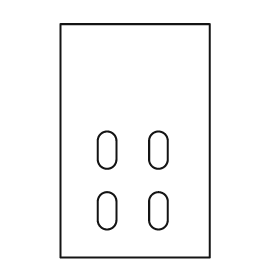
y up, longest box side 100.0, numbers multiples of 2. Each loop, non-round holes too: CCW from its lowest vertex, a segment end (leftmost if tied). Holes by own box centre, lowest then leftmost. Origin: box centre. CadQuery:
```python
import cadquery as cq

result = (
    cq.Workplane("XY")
    .moveTo(-32.0, -50.0)
    .lineTo(32.0, -50.0)
    .lineTo(32.0, 50.0)
    .lineTo(-32.0, 50.0)
    .close()
    .moveTo(-16.0, -34.0)
    .threePointArc((-12.0, -38.0), (-8.0, -34.0))
    .lineTo(-8.0, -26.0)
    .threePointArc((-12.0, -22.0), (-16.0, -26.0))
    .close()
    .moveTo(6.0, -34.0)
    .threePointArc((10.0, -38.0), (14.0, -34.0))
    .lineTo(14.0, -26.0)
    .threePointArc((10.0, -22.0), (6.0, -26.0))
    .close()
    .moveTo(-16.0, -8.0)
    .threePointArc((-12.0, -12.0), (-8.0, -8.0))
    .lineTo(-8.0, 0.0)
    .threePointArc((-12.0, 4.0), (-16.0, 0.0))
    .close()
    .moveTo(6.0, -8.0)
    .threePointArc((10.0, -12.0), (14.0, -8.0))
    .lineTo(14.0, 0.0)
    .threePointArc((10.0, 4.0), (6.0, 0.0))
    .close()
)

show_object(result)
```